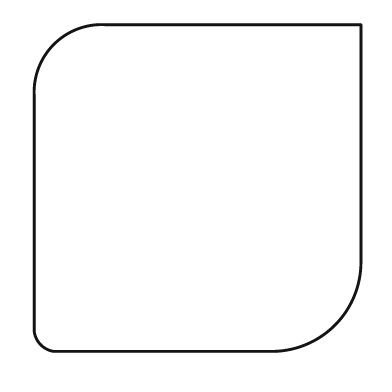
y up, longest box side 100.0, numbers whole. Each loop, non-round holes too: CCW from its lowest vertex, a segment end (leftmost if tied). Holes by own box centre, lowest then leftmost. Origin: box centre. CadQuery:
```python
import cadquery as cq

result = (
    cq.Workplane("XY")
    .moveTo(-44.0, -50.0)
    .lineTo(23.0, -50.0)
    .threePointArc((42.0, -42.0), (50.0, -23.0))
    .lineTo(50.0, 50.0)
    .lineTo(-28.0, 50.0)
    .threePointArc((-44.0, 44.0), (-50.0, 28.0))
    .lineTo(-50.0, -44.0)
    .threePointArc((-48.0, -48.0), (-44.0, -50.0))
    .close()
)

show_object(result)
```